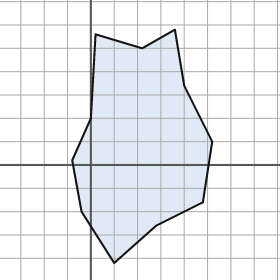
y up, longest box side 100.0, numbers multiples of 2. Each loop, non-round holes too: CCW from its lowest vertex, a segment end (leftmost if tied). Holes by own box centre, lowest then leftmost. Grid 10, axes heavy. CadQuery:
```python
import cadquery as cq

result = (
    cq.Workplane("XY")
    .moveTo(10.0, -42.0)
    .lineTo(28.0, -26.0)
    .lineTo(48.0, -16.0)
    .lineTo(52.0, 10.0)
    .lineTo(40.0, 34.0)
    .lineTo(36.0, 58.0)
    .lineTo(22.0, 50.0)
    .lineTo(2.0, 56.0)
    .lineTo(0.0, 20.0)
    .lineTo(-8.0, 2.0)
    .lineTo(-4.0, -20.0)
    .close()
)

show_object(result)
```